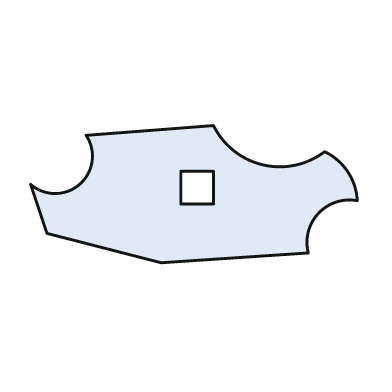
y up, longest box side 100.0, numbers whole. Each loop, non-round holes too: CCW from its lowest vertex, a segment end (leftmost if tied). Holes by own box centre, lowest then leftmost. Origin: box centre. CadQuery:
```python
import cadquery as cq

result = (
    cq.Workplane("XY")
    .moveTo(-10.0, -21.0)
    .lineTo(35.0, -18.0)
    .threePointArc((38.0, -6.0), (50.0, -2.0))
    .threePointArc((47.0, 7.0), (40.0, 13.0))
    .threePointArc((21.0, 9.0), (6.0, 21.0))
    .lineTo(-33.0, 18.0)
    .threePointArc((-35.0, 3.0), (-50.0, 3.0))
    .lineTo(-45.0, -12.0)
    .close()
    .moveTo(-4.0, -3.0)
    .lineTo(6.0, -3.0)
    .lineTo(6.0, 7.0)
    .lineTo(-4.0, 7.0)
    .close()
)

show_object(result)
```